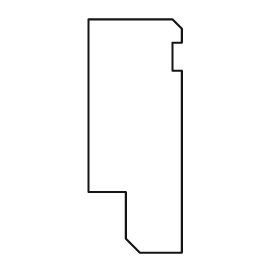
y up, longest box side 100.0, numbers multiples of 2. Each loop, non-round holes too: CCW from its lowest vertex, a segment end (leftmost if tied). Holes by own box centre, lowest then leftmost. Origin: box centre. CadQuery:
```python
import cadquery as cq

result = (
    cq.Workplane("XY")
    .moveTo(2.0, -50.0)
    .lineTo(20.0, -50.0)
    .lineTo(20.0, 28.0)
    .lineTo(16.0, 28.0)
    .lineTo(16.0, 40.0)
    .lineTo(20.0, 40.0)
    .lineTo(20.0, 46.0)
    .lineTo(16.0, 50.0)
    .lineTo(-20.0, 50.0)
    .lineTo(-20.0, -24.0)
    .lineTo(-4.0, -24.0)
    .lineTo(-4.0, -44.0)
    .close()
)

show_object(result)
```